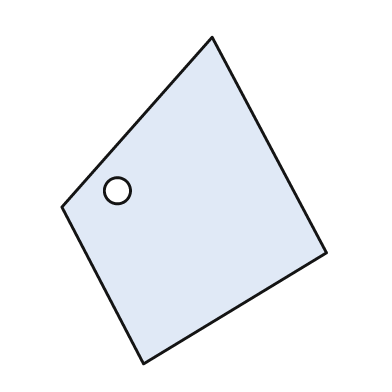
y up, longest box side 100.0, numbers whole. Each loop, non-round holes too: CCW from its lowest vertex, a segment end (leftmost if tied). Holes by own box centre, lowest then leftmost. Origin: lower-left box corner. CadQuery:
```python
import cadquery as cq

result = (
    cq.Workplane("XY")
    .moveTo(25.0, 0.0)
    .lineTo(81.0, 34.0)
    .lineTo(46.0, 100.0)
    .lineTo(0.0, 48.0)
    .close()
    .moveTo(17.0, 53.0)
    .circle(4.0)
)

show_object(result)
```